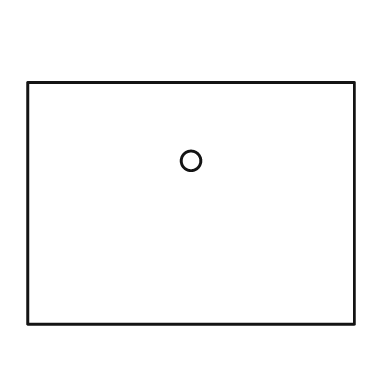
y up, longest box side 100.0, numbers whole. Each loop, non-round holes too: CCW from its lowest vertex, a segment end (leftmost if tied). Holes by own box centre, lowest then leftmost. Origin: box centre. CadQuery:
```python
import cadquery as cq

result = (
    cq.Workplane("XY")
    .moveTo(-50.0, -37.0)
    .lineTo(50.0, -37.0)
    .lineTo(50.0, 37.0)
    .lineTo(-50.0, 37.0)
    .close()
    .moveTo(0.0, 13.0)
    .circle(3.0)
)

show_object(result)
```